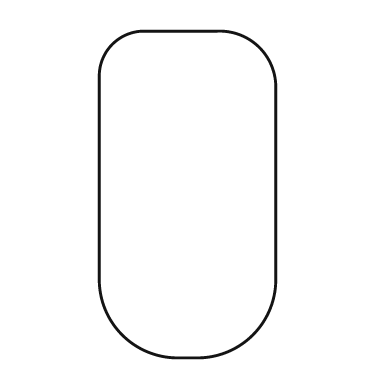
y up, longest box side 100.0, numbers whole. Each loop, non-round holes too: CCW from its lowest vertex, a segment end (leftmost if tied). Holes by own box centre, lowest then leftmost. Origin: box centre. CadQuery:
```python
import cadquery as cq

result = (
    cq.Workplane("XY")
    .moveTo(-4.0, -50.0)
    .lineTo(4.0, -50.0)
    .threePointArc((20.0, -43.0), (27.0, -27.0))
    .lineTo(27.0, 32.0)
    .threePointArc((22.0, 45.0), (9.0, 50.0))
    .lineTo(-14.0, 50.0)
    .threePointArc((-23.0, 46.0), (-27.0, 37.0))
    .lineTo(-27.0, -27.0)
    .threePointArc((-20.0, -43.0), (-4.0, -50.0))
    .close()
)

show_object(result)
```